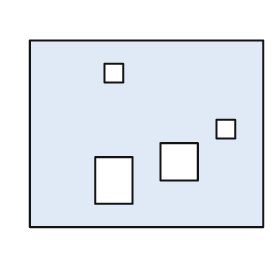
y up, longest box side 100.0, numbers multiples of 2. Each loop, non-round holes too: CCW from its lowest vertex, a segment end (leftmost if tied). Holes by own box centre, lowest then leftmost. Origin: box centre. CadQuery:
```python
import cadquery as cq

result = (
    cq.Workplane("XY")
    .moveTo(-50.0, -40.0)
    .lineTo(50.0, -40.0)
    .lineTo(50.0, 40.0)
    .lineTo(-50.0, 40.0)
    .close()
    .moveTo(-22.0, -30.0)
    .lineTo(-6.0, -30.0)
    .lineTo(-6.0, -10.0)
    .lineTo(-22.0, -10.0)
    .close()
    .moveTo(6.0, -20.0)
    .lineTo(22.0, -20.0)
    .lineTo(22.0, -4.0)
    .lineTo(6.0, -4.0)
    .close()
    .moveTo(30.0, -2.0)
    .lineTo(38.0, -2.0)
    .lineTo(38.0, 6.0)
    .lineTo(30.0, 6.0)
    .close()
    .moveTo(-18.0, 22.0)
    .lineTo(-10.0, 22.0)
    .lineTo(-10.0, 30.0)
    .lineTo(-18.0, 30.0)
    .close()
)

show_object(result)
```